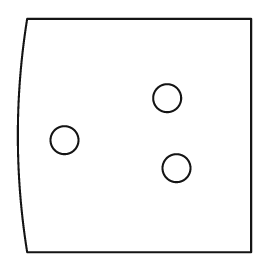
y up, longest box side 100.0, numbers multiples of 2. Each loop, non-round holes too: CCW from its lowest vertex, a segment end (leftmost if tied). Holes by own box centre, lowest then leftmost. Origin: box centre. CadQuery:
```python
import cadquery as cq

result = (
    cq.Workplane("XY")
    .moveTo(-46.0, -50.0)
    .lineTo(50.0, -50.0)
    .lineTo(50.0, 50.0)
    .lineTo(-46.0, 50.0)
    .threePointArc((-50.0, 0.0), (-46.0, -50.0))
    .close()
    .moveTo(18.0, -14.0)
    .circle(6.0)
    .moveTo(-30.0, -2.0)
    .circle(6.0)
    .moveTo(14.0, 16.0)
    .circle(6.0)
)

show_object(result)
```